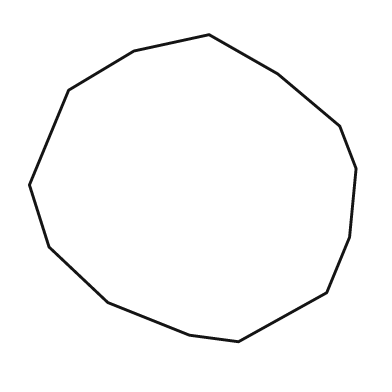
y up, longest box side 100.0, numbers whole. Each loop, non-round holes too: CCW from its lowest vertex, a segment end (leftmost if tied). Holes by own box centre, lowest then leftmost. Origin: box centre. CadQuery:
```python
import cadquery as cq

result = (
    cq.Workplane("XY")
    .moveTo(14.0, -47.0)
    .lineTo(41.0, -32.0)
    .lineTo(48.0, -15.0)
    .lineTo(50.0, 6.0)
    .lineTo(45.0, 19.0)
    .lineTo(26.0, 35.0)
    .lineTo(5.0, 47.0)
    .lineTo(-18.0, 42.0)
    .lineTo(-38.0, 30.0)
    .lineTo(-50.0, 1.0)
    .lineTo(-44.0, -18.0)
    .lineTo(-26.0, -35.0)
    .lineTo(-1.0, -45.0)
    .close()
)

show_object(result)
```